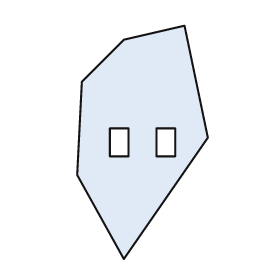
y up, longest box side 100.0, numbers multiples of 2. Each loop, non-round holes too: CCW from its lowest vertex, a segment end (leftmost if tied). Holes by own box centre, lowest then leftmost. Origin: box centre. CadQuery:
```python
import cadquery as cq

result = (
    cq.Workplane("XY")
    .moveTo(-8.0, -50.0)
    .lineTo(28.0, 2.0)
    .lineTo(18.0, 50.0)
    .lineTo(-8.0, 44.0)
    .lineTo(-26.0, 26.0)
    .lineTo(-28.0, -14.0)
    .close()
    .moveTo(-14.0, -6.0)
    .lineTo(-6.0, -6.0)
    .lineTo(-6.0, 6.0)
    .lineTo(-14.0, 6.0)
    .close()
    .moveTo(6.0, -6.0)
    .lineTo(14.0, -6.0)
    .lineTo(14.0, 6.0)
    .lineTo(6.0, 6.0)
    .close()
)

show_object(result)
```